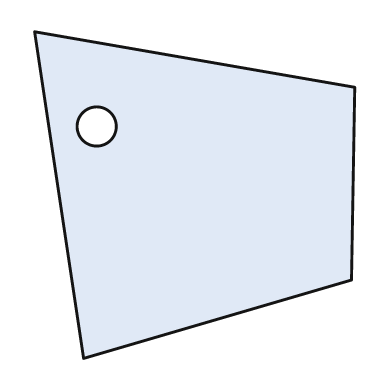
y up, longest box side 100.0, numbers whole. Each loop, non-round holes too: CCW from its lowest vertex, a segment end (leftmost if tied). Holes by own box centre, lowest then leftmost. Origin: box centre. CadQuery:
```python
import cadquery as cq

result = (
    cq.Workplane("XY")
    .moveTo(-34.0, -50.0)
    .lineTo(48.0, -26.0)
    .lineTo(49.0, 33.0)
    .lineTo(-49.0, 50.0)
    .close()
    .moveTo(-30.0, 21.0)
    .circle(6.0)
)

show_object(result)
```